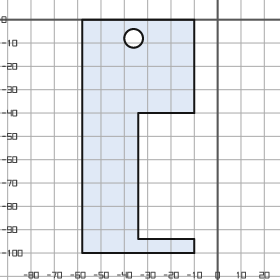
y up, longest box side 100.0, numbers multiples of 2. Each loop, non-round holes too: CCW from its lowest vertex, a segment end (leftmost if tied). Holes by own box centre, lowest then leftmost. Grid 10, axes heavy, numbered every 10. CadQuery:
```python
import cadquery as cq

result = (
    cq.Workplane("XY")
    .moveTo(-58.0, -100.0)
    .lineTo(-10.0, -100.0)
    .lineTo(-10.0, -94.0)
    .lineTo(-34.0, -94.0)
    .lineTo(-34.0, -40.0)
    .lineTo(-10.0, -40.0)
    .lineTo(-10.0, 0.0)
    .lineTo(-58.0, 0.0)
    .close()
    .moveTo(-36.0, -8.0)
    .circle(4.0)
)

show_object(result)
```